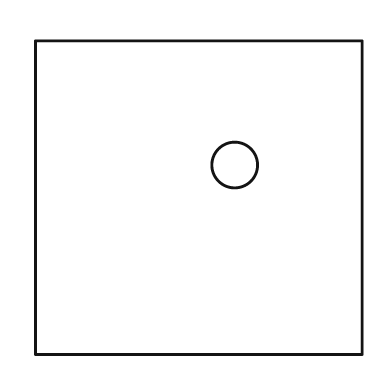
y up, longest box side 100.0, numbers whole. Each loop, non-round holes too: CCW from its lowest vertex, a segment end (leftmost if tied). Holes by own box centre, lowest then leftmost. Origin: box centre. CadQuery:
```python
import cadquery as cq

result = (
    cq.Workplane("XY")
    .moveTo(-50.0, -48.0)
    .lineTo(50.0, -48.0)
    .lineTo(50.0, 48.0)
    .lineTo(-50.0, 48.0)
    .close()
    .moveTo(11.0, 10.0)
    .circle(7.0)
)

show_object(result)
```